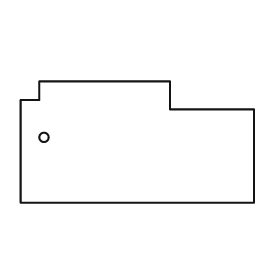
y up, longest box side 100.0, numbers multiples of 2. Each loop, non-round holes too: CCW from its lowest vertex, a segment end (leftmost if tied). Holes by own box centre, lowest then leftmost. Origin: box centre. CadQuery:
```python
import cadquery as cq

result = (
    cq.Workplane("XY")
    .moveTo(-50.0, -26.0)
    .lineTo(50.0, -26.0)
    .lineTo(50.0, 14.0)
    .lineTo(14.0, 14.0)
    .lineTo(14.0, 26.0)
    .lineTo(-42.0, 26.0)
    .lineTo(-42.0, 18.0)
    .lineTo(-50.0, 18.0)
    .close()
    .moveTo(-40.0, 2.0)
    .circle(2.0)
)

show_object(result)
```